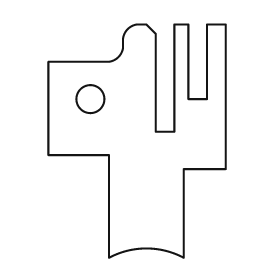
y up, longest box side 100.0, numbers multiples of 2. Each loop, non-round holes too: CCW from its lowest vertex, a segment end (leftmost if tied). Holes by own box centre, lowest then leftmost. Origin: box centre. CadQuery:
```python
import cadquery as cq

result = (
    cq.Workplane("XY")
    .moveTo(-12.0, -50.0)
    .threePointArc((4.0, -46.0), (20.0, -50.0))
    .lineTo(20.0, -12.0)
    .lineTo(38.0, -12.0)
    .lineTo(38.0, 50.0)
    .lineTo(30.0, 50.0)
    .lineTo(30.0, 18.0)
    .lineTo(22.0, 18.0)
    .lineTo(22.0, 50.0)
    .lineTo(16.0, 50.0)
    .lineTo(16.0, 4.0)
    .lineTo(8.0, 4.0)
    .lineTo(8.0, 46.0)
    .lineTo(4.0, 50.0)
    .lineTo(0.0, 50.0)
    .threePointArc((-4.0, 48.0), (-6.0, 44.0))
    .lineTo(-6.0, 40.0)
    .threePointArc((-8.0, 36.0), (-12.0, 34.0))
    .lineTo(-38.0, 34.0)
    .lineTo(-38.0, -6.0)
    .lineTo(-12.0, -6.0)
    .close()
    .moveTo(-20.0, 18.0)
    .circle(6.0)
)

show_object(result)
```